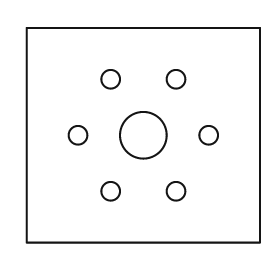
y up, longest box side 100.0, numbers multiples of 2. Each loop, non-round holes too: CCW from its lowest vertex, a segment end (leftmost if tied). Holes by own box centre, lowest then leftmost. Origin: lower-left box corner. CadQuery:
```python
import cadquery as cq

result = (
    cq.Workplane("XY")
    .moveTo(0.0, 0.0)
    .lineTo(100.0, 0.0)
    .lineTo(100.0, 92.0)
    .lineTo(0.0, 92.0)
    .close()
    .moveTo(36.0, 22.0)
    .circle(4.0)
    .moveTo(64.0, 22.0)
    .circle(4.0)
    .moveTo(22.0, 46.0)
    .circle(4.0)
    .moveTo(50.0, 46.0)
    .circle(10.0)
    .moveTo(78.0, 46.0)
    .circle(4.0)
    .moveTo(36.0, 70.0)
    .circle(4.0)
    .moveTo(64.0, 70.0)
    .circle(4.0)
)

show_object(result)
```